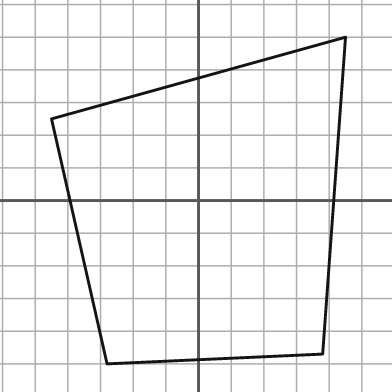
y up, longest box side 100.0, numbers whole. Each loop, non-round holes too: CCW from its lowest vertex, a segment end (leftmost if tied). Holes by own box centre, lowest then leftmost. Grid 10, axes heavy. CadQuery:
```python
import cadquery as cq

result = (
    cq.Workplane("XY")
    .moveTo(-28.0, -50.0)
    .lineTo(38.0, -47.0)
    .lineTo(45.0, 50.0)
    .lineTo(-45.0, 25.0)
    .close()
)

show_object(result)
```